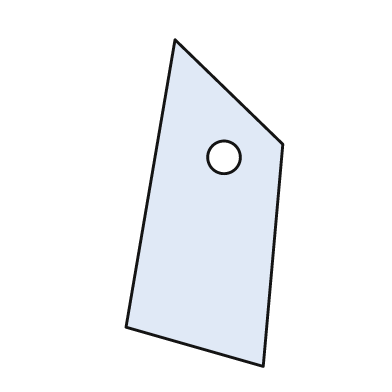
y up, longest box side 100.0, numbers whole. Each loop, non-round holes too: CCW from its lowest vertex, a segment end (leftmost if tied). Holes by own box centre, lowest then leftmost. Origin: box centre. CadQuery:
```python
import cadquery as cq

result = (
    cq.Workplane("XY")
    .moveTo(18.0, -50.0)
    .lineTo(24.0, 18.0)
    .lineTo(-9.0, 50.0)
    .lineTo(-24.0, -38.0)
    .close()
    .moveTo(6.0, 14.0)
    .circle(5.0)
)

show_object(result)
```